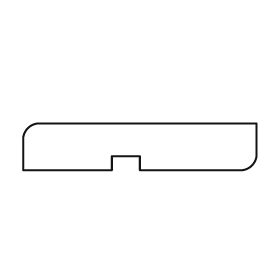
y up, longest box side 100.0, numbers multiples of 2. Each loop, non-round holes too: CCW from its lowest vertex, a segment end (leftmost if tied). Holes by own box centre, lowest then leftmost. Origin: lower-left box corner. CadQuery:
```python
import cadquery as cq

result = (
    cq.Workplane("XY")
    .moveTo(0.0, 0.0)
    .lineTo(38.0, 0.0)
    .lineTo(38.0, 6.0)
    .lineTo(50.0, 6.0)
    .lineTo(50.0, 0.0)
    .lineTo(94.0, 0.0)
    .threePointArc((98.0, 2.0), (100.0, 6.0))
    .lineTo(100.0, 20.0)
    .lineTo(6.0, 20.0)
    .threePointArc((2.0, 18.0), (0.0, 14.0))
    .close()
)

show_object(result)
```